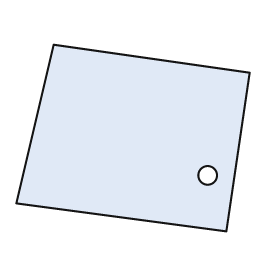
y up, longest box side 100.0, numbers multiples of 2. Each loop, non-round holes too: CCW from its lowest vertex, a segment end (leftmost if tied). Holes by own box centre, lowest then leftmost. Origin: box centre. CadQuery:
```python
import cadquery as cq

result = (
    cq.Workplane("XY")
    .moveTo(40.0, -40.0)
    .lineTo(50.0, 28.0)
    .lineTo(-34.0, 40.0)
    .lineTo(-50.0, -28.0)
    .close()
    .moveTo(32.0, -16.0)
    .circle(4.0)
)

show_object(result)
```